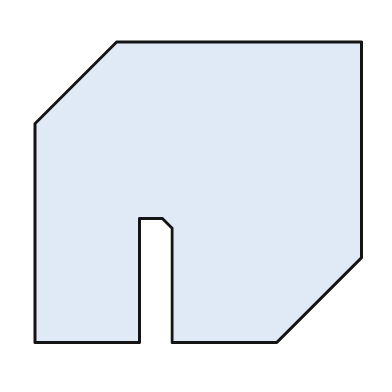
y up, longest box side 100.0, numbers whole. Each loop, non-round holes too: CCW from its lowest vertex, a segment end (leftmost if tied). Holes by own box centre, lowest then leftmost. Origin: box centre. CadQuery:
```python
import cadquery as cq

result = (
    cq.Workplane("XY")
    .moveTo(-50.0, -46.0)
    .lineTo(-18.0, -46.0)
    .lineTo(-18.0, -8.0)
    .lineTo(-11.0, -8.0)
    .lineTo(-8.0, -11.0)
    .lineTo(-8.0, -46.0)
    .lineTo(24.0, -46.0)
    .lineTo(50.0, -20.0)
    .lineTo(50.0, 46.0)
    .lineTo(-25.0, 46.0)
    .lineTo(-50.0, 21.0)
    .close()
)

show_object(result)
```